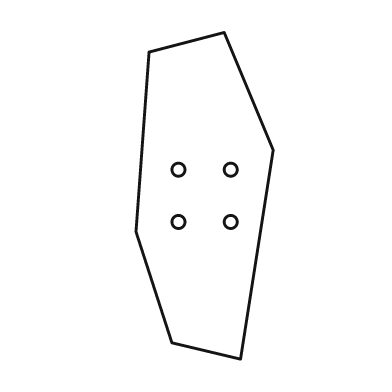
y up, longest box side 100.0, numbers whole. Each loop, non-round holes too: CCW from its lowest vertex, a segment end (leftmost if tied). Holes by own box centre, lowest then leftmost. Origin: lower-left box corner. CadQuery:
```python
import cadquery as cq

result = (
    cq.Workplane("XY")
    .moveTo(32.0, 0.0)
    .lineTo(42.0, 64.0)
    .lineTo(27.0, 100.0)
    .lineTo(4.0, 94.0)
    .lineTo(0.0, 39.0)
    .lineTo(11.0, 5.0)
    .close()
    .moveTo(13.0, 42.0)
    .circle(2.0)
    .moveTo(29.0, 42.0)
    .circle(2.0)
    .moveTo(13.0, 58.0)
    .circle(2.0)
    .moveTo(29.0, 58.0)
    .circle(2.0)
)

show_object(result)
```